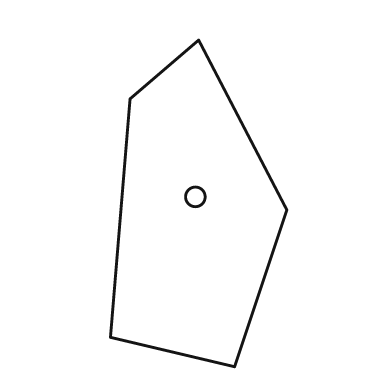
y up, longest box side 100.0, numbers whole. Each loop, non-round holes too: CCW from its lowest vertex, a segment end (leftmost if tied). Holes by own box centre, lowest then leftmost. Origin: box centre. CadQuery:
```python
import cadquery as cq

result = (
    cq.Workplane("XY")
    .moveTo(11.0, -50.0)
    .lineTo(27.0, -2.0)
    .lineTo(0.0, 50.0)
    .lineTo(-21.0, 32.0)
    .lineTo(-27.0, -41.0)
    .close()
    .moveTo(-1.0, 2.0)
    .circle(3.0)
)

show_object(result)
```